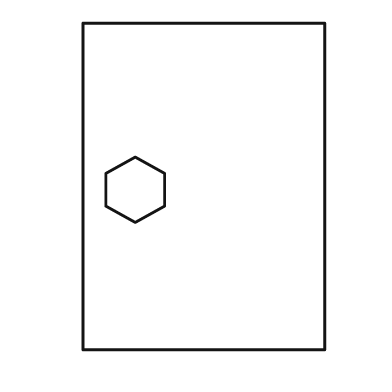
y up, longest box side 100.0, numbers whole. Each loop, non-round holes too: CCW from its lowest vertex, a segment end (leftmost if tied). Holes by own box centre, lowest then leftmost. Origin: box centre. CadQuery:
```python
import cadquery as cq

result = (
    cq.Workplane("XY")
    .moveTo(-37.0, -50.0)
    .lineTo(37.0, -50.0)
    .lineTo(37.0, 50.0)
    .lineTo(-37.0, 50.0)
    .close()
    .moveTo(-21.0, -11.0)
    .lineTo(-12.0, -6.0)
    .lineTo(-12.0, 4.0)
    .lineTo(-21.0, 9.0)
    .lineTo(-30.0, 4.0)
    .lineTo(-30.0, -6.0)
    .close()
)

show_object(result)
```